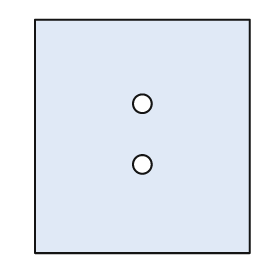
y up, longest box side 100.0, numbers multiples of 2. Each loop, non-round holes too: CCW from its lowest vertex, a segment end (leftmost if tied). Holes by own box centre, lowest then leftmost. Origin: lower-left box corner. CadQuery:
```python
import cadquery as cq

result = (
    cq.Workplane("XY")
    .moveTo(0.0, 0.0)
    .lineTo(92.0, 0.0)
    .lineTo(92.0, 100.0)
    .lineTo(0.0, 100.0)
    .close()
    .moveTo(46.0, 38.0)
    .circle(4.0)
    .moveTo(46.0, 64.0)
    .circle(4.0)
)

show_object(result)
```